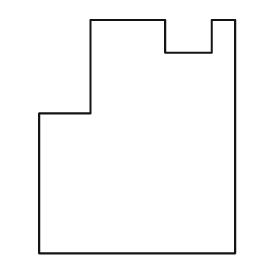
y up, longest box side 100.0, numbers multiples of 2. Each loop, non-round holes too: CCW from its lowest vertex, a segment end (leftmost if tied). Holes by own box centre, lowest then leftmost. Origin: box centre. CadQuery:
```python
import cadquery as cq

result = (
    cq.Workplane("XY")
    .moveTo(-42.0, -50.0)
    .lineTo(42.0, -50.0)
    .lineTo(42.0, 50.0)
    .lineTo(32.0, 50.0)
    .lineTo(32.0, 36.0)
    .lineTo(12.0, 36.0)
    .lineTo(12.0, 50.0)
    .lineTo(-20.0, 50.0)
    .lineTo(-20.0, 10.0)
    .lineTo(-42.0, 10.0)
    .close()
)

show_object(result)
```